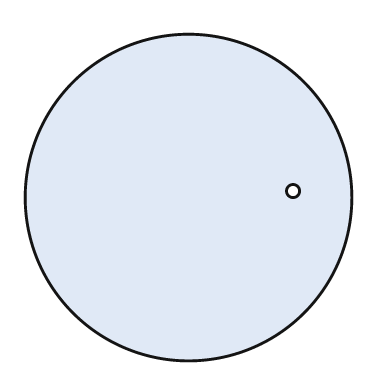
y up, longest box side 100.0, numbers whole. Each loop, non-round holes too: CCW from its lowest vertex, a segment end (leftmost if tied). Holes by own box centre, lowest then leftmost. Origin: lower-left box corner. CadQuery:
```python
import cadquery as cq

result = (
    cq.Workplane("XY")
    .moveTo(50.0, 50.0)
    .circle(50.0)
    .moveTo(82.0, 52.0)
    .circle(2.0)
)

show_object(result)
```